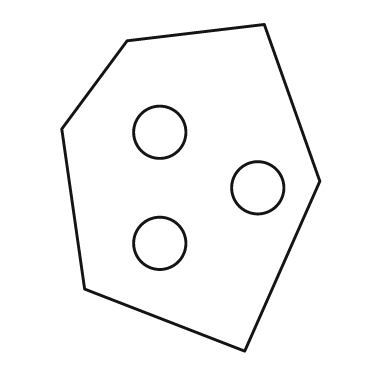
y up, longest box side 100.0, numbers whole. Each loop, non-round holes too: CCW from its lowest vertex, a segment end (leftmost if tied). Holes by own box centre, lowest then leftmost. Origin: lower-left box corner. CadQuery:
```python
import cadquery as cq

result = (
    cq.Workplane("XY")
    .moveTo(56.0, 0.0)
    .lineTo(79.0, 52.0)
    .lineTo(62.0, 100.0)
    .lineTo(20.0, 95.0)
    .lineTo(0.0, 68.0)
    .lineTo(7.0, 19.0)
    .close()
    .moveTo(30.0, 33.0)
    .circle(8.0)
    .moveTo(60.0, 50.0)
    .circle(8.0)
    .moveTo(30.0, 67.0)
    .circle(8.0)
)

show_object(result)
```